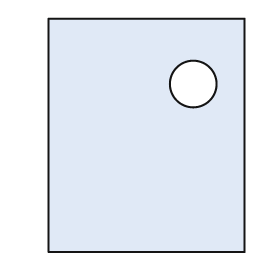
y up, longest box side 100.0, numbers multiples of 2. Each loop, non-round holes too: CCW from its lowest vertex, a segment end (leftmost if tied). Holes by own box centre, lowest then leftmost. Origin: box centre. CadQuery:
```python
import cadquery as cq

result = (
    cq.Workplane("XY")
    .moveTo(-42.0, -50.0)
    .lineTo(42.0, -50.0)
    .lineTo(42.0, 50.0)
    .lineTo(-42.0, 50.0)
    .close()
    .moveTo(20.0, 22.0)
    .circle(10.0)
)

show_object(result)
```